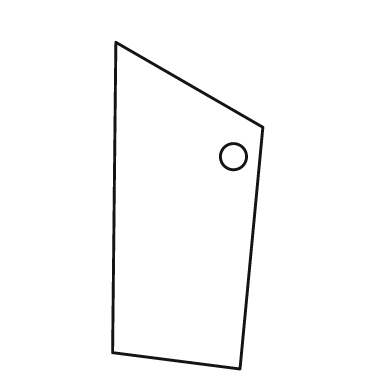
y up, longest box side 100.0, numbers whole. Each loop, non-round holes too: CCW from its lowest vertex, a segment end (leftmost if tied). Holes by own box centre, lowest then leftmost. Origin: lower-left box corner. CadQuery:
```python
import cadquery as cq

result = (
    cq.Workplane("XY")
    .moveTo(39.0, 0.0)
    .lineTo(46.0, 74.0)
    .lineTo(1.0, 100.0)
    .lineTo(0.0, 5.0)
    .close()
    .moveTo(37.0, 65.0)
    .circle(4.0)
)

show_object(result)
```